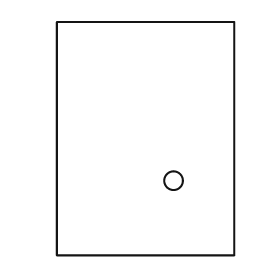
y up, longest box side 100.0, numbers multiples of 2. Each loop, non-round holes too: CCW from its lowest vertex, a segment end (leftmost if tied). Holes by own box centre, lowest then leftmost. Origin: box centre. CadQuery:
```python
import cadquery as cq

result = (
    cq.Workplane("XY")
    .moveTo(-38.0, -50.0)
    .lineTo(38.0, -50.0)
    .lineTo(38.0, 50.0)
    .lineTo(-38.0, 50.0)
    .close()
    .moveTo(12.0, -18.0)
    .circle(4.0)
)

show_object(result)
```